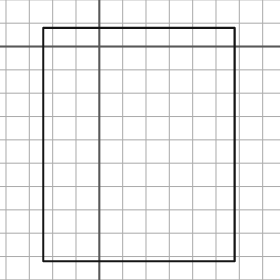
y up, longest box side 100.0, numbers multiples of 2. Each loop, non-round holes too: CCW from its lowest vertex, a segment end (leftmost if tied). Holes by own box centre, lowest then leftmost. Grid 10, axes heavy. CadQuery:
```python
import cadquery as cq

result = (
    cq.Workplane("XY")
    .moveTo(-24.0, -92.0)
    .lineTo(58.0, -92.0)
    .lineTo(58.0, 8.0)
    .lineTo(-24.0, 8.0)
    .close()
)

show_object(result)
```